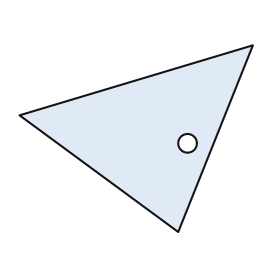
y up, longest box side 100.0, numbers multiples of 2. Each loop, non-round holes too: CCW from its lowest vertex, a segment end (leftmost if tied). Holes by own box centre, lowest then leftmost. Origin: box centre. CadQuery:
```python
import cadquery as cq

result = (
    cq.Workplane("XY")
    .moveTo(18.0, -40.0)
    .lineTo(50.0, 40.0)
    .lineTo(-50.0, 10.0)
    .close()
    .moveTo(22.0, -2.0)
    .circle(4.0)
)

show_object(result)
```